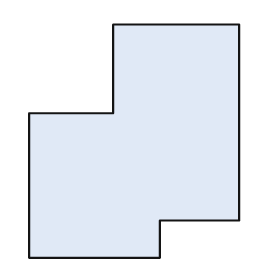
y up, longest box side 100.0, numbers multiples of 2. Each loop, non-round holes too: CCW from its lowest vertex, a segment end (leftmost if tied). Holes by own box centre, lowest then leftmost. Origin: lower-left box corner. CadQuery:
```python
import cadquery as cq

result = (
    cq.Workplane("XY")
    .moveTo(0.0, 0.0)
    .lineTo(56.0, 0.0)
    .lineTo(56.0, 16.0)
    .lineTo(90.0, 16.0)
    .lineTo(90.0, 100.0)
    .lineTo(36.0, 100.0)
    .lineTo(36.0, 62.0)
    .lineTo(0.0, 62.0)
    .close()
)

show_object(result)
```